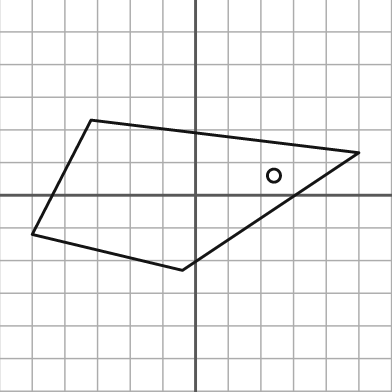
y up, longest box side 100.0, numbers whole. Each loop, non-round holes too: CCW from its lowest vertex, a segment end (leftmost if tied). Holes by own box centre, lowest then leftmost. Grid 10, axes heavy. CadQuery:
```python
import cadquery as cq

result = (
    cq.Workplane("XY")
    .moveTo(-4.0, -23.0)
    .lineTo(50.0, 13.0)
    .lineTo(-32.0, 23.0)
    .lineTo(-50.0, -12.0)
    .close()
    .moveTo(24.0, 6.0)
    .circle(2.0)
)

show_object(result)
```